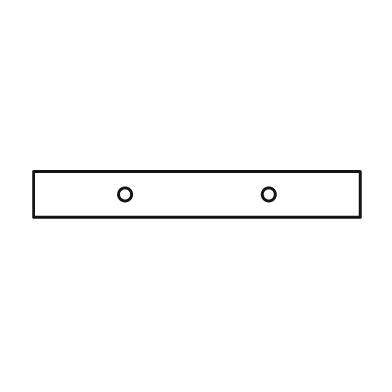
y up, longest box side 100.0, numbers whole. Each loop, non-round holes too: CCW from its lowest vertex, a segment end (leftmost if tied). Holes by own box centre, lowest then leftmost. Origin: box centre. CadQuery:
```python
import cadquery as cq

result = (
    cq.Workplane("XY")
    .moveTo(-50.0, -7.0)
    .lineTo(50.0, -7.0)
    .lineTo(50.0, 7.0)
    .lineTo(-50.0, 7.0)
    .close()
    .moveTo(-22.0, 0.0)
    .circle(2.0)
    .moveTo(22.0, 0.0)
    .circle(2.0)
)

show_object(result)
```